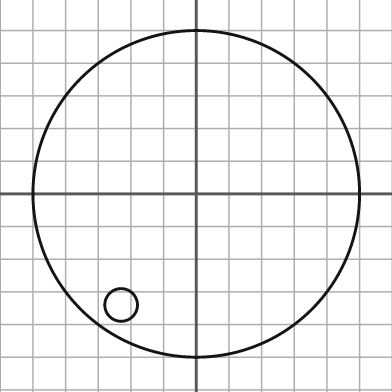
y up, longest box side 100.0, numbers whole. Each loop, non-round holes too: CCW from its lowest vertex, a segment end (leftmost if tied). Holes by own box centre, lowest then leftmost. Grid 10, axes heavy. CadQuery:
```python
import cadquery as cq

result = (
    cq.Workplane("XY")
    .moveTo(0.0, 0.0)
    .circle(50.0)
    .moveTo(-23.0, -34.0)
    .circle(5.0)
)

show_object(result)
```